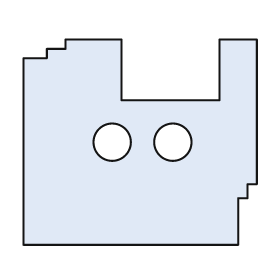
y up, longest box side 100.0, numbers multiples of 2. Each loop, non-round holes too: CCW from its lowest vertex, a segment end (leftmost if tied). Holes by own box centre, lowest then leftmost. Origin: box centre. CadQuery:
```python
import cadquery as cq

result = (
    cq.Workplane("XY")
    .moveTo(-50.0, -44.0)
    .lineTo(42.0, -44.0)
    .lineTo(42.0, -24.0)
    .lineTo(46.0, -24.0)
    .lineTo(46.0, -18.0)
    .lineTo(50.0, -18.0)
    .lineTo(50.0, 44.0)
    .lineTo(34.0, 44.0)
    .lineTo(34.0, 18.0)
    .lineTo(-8.0, 18.0)
    .lineTo(-8.0, 44.0)
    .lineTo(-32.0, 44.0)
    .lineTo(-32.0, 40.0)
    .lineTo(-40.0, 40.0)
    .lineTo(-40.0, 36.0)
    .lineTo(-50.0, 36.0)
    .close()
    .moveTo(-12.0, 0.0)
    .circle(8.0)
    .moveTo(14.0, 0.0)
    .circle(8.0)
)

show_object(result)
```